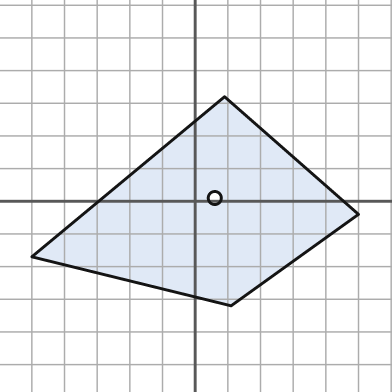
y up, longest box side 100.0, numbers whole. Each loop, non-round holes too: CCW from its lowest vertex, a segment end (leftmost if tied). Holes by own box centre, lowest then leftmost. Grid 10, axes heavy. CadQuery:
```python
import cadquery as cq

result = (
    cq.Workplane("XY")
    .moveTo(11.0, -32.0)
    .lineTo(50.0, -4.0)
    .lineTo(9.0, 32.0)
    .lineTo(-50.0, -17.0)
    .close()
    .moveTo(6.0, 1.0)
    .circle(2.0)
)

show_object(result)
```